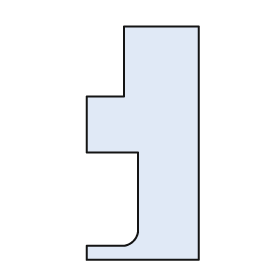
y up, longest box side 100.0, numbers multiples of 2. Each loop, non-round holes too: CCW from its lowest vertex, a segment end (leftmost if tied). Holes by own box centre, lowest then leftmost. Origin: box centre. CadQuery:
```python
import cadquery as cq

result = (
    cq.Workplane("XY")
    .moveTo(-24.0, -50.0)
    .lineTo(24.0, -50.0)
    .lineTo(24.0, 50.0)
    .lineTo(-8.0, 50.0)
    .lineTo(-8.0, 20.0)
    .lineTo(-24.0, 20.0)
    .lineTo(-24.0, -4.0)
    .lineTo(-2.0, -4.0)
    .lineTo(-2.0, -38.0)
    .threePointArc((-4.0, -42.0), (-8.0, -44.0))
    .lineTo(-24.0, -44.0)
    .close()
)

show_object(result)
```